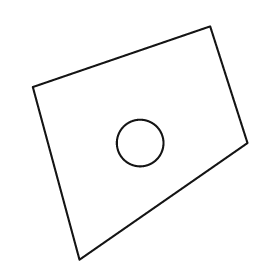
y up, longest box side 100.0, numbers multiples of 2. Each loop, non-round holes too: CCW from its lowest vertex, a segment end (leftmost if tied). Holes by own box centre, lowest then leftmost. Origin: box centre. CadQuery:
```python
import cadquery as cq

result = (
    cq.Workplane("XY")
    .moveTo(-26.0, -50.0)
    .lineTo(46.0, 0.0)
    .lineTo(30.0, 50.0)
    .lineTo(-46.0, 24.0)
    .close()
    .moveTo(0.0, 0.0)
    .circle(10.0)
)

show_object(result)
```